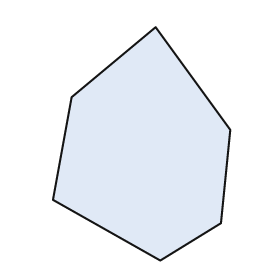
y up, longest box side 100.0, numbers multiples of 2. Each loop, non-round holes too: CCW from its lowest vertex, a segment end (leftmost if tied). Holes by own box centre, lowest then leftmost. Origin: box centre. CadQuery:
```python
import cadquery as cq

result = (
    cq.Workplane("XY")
    .moveTo(8.0, -50.0)
    .lineTo(34.0, -34.0)
    .lineTo(38.0, 6.0)
    .lineTo(6.0, 50.0)
    .lineTo(-30.0, 20.0)
    .lineTo(-38.0, -24.0)
    .close()
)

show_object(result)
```